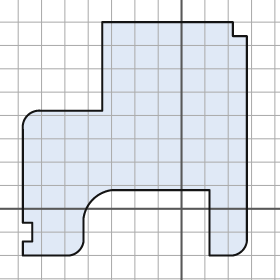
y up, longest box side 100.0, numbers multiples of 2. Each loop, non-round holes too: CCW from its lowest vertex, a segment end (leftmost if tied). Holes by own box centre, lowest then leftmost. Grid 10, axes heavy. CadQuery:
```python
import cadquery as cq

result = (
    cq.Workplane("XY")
    .moveTo(-68.0, -20.0)
    .lineTo(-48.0, -20.0)
    .threePointArc((-44.0, -18.0), (-42.0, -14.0))
    .lineTo(-42.0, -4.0)
    .threePointArc((-38.0, 4.0), (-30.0, 8.0))
    .lineTo(12.0, 8.0)
    .lineTo(12.0, -20.0)
    .lineTo(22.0, -20.0)
    .threePointArc((26.0, -18.0), (28.0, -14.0))
    .lineTo(28.0, 74.0)
    .lineTo(22.0, 74.0)
    .lineTo(22.0, 80.0)
    .lineTo(-34.0, 80.0)
    .lineTo(-34.0, 42.0)
    .lineTo(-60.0, 42.0)
    .threePointArc((-66.0, 40.0), (-68.0, 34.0))
    .lineTo(-68.0, -6.0)
    .lineTo(-64.0, -6.0)
    .lineTo(-64.0, -14.0)
    .lineTo(-68.0, -14.0)
    .close()
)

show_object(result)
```